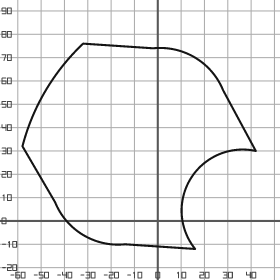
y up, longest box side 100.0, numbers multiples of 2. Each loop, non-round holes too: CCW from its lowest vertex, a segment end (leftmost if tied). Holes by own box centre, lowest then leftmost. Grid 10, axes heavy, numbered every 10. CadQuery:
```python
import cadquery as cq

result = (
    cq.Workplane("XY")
    .moveTo(16.0, -12.0)
    .threePointArc((14.0, 18.0), (42.0, 30.0))
    .lineTo(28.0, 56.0)
    .threePointArc((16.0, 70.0), (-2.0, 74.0))
    .lineTo(-32.0, 76.0)
    .threePointArc((-48.0, 56.0), (-58.0, 32.0))
    .lineTo(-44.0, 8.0)
    .threePointArc((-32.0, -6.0), (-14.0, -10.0))
    .close()
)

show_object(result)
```